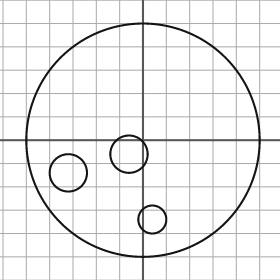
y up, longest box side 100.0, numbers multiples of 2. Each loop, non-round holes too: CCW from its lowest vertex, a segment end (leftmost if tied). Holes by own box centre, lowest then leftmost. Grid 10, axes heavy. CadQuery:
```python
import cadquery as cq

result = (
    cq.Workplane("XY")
    .moveTo(0.0, 0.0)
    .circle(50.0)
    .moveTo(4.0, -34.0)
    .circle(6.0)
    .moveTo(-32.0, -14.0)
    .circle(8.0)
    .moveTo(-6.0, -6.0)
    .circle(8.0)
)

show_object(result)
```